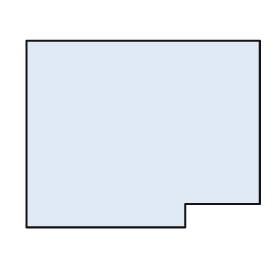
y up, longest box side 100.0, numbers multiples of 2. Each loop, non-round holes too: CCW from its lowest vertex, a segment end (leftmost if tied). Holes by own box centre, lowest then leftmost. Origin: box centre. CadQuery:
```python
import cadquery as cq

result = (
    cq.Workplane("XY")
    .moveTo(-50.0, -40.0)
    .lineTo(18.0, -40.0)
    .lineTo(18.0, -30.0)
    .lineTo(50.0, -30.0)
    .lineTo(50.0, 40.0)
    .lineTo(-50.0, 40.0)
    .close()
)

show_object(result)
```